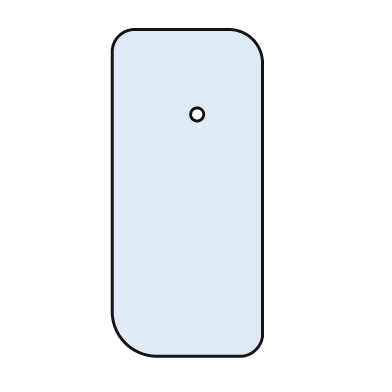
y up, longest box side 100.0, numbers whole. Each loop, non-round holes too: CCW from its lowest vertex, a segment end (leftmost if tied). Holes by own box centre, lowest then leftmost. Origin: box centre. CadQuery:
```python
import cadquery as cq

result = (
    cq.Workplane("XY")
    .moveTo(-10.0, -50.0)
    .lineTo(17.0, -50.0)
    .threePointArc((21.0, -48.0), (23.0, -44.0))
    .lineTo(23.0, 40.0)
    .threePointArc((20.0, 47.0), (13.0, 50.0))
    .lineTo(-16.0, 50.0)
    .threePointArc((-21.0, 48.0), (-23.0, 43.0))
    .lineTo(-23.0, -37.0)
    .threePointArc((-19.0, -46.0), (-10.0, -50.0))
    .close()
    .moveTo(3.0, 24.0)
    .circle(2.0)
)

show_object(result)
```